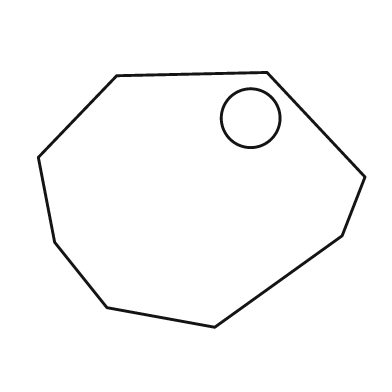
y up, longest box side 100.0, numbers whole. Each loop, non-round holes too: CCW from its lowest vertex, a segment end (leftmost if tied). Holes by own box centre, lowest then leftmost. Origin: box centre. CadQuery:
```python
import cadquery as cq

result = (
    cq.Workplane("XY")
    .moveTo(4.0, -39.0)
    .lineTo(43.0, -11.0)
    .lineTo(50.0, 7.0)
    .lineTo(20.0, 39.0)
    .lineTo(-26.0, 38.0)
    .lineTo(-50.0, 13.0)
    .lineTo(-45.0, -13.0)
    .lineTo(-29.0, -33.0)
    .close()
    .moveTo(15.0, 25.0)
    .circle(9.0)
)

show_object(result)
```